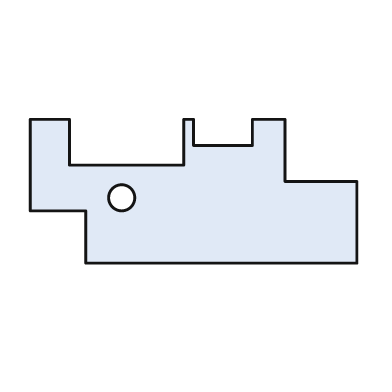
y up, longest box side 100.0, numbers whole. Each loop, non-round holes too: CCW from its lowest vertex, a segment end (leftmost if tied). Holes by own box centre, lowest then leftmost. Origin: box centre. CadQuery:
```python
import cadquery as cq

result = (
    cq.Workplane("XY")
    .moveTo(-33.0, -22.0)
    .lineTo(50.0, -22.0)
    .lineTo(50.0, 3.0)
    .lineTo(28.0, 3.0)
    .lineTo(28.0, 22.0)
    .lineTo(18.0, 22.0)
    .lineTo(18.0, 14.0)
    .lineTo(0.0, 14.0)
    .lineTo(0.0, 22.0)
    .lineTo(-3.0, 22.0)
    .lineTo(-3.0, 8.0)
    .lineTo(-38.0, 8.0)
    .lineTo(-38.0, 22.0)
    .lineTo(-50.0, 22.0)
    .lineTo(-50.0, -6.0)
    .lineTo(-33.0, -6.0)
    .close()
    .moveTo(-22.0, -2.0)
    .circle(4.0)
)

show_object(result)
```